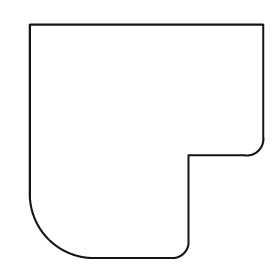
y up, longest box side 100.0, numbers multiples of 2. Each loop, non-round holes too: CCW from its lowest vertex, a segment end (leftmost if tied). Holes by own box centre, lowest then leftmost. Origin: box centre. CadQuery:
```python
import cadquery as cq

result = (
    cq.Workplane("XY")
    .moveTo(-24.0, -50.0)
    .lineTo(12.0, -50.0)
    .threePointArc((16.0, -48.0), (18.0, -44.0))
    .lineTo(18.0, -6.0)
    .lineTo(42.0, -6.0)
    .threePointArc((48.0, -4.0), (50.0, 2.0))
    .lineTo(50.0, 50.0)
    .lineTo(-50.0, 50.0)
    .lineTo(-50.0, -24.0)
    .threePointArc((-42.0, -42.0), (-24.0, -50.0))
    .close()
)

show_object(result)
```